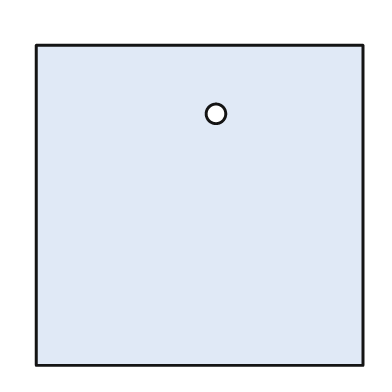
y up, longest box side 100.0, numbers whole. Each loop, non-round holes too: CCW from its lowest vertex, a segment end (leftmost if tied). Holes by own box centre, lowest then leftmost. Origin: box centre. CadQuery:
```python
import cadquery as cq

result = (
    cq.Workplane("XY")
    .moveTo(-50.0, -49.0)
    .lineTo(50.0, -49.0)
    .lineTo(50.0, 49.0)
    .lineTo(-50.0, 49.0)
    .close()
    .moveTo(5.0, 28.0)
    .circle(3.0)
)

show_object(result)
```